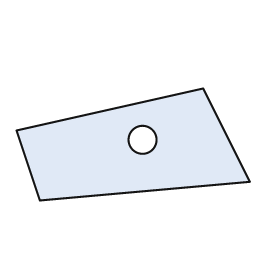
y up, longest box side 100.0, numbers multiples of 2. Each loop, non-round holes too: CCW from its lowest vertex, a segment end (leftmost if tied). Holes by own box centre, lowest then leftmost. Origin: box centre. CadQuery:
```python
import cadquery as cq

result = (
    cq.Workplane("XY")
    .moveTo(-40.0, -24.0)
    .lineTo(50.0, -16.0)
    .lineTo(30.0, 24.0)
    .lineTo(-50.0, 6.0)
    .close()
    .moveTo(4.0, 2.0)
    .circle(6.0)
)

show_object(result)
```